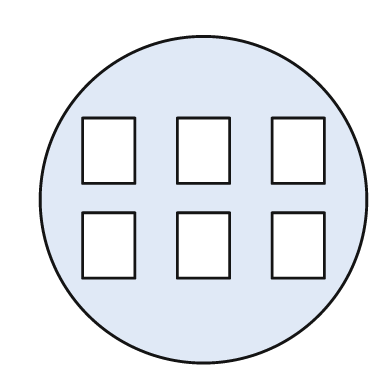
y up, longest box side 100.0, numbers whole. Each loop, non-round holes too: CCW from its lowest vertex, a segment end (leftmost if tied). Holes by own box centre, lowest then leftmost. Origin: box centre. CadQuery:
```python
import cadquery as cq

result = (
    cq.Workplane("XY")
    .moveTo(0.0, 0.0)
    .circle(50.0)
    .moveTo(-37.0, -24.0)
    .lineTo(-21.0, -24.0)
    .lineTo(-21.0, -4.0)
    .lineTo(-37.0, -4.0)
    .close()
    .moveTo(-8.0, -24.0)
    .lineTo(8.0, -24.0)
    .lineTo(8.0, -4.0)
    .lineTo(-8.0, -4.0)
    .close()
    .moveTo(21.0, -24.0)
    .lineTo(37.0, -24.0)
    .lineTo(37.0, -4.0)
    .lineTo(21.0, -4.0)
    .close()
    .moveTo(-37.0, 5.0)
    .lineTo(-21.0, 5.0)
    .lineTo(-21.0, 25.0)
    .lineTo(-37.0, 25.0)
    .close()
    .moveTo(-8.0, 5.0)
    .lineTo(8.0, 5.0)
    .lineTo(8.0, 25.0)
    .lineTo(-8.0, 25.0)
    .close()
    .moveTo(21.0, 5.0)
    .lineTo(37.0, 5.0)
    .lineTo(37.0, 25.0)
    .lineTo(21.0, 25.0)
    .close()
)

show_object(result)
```